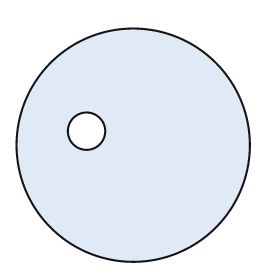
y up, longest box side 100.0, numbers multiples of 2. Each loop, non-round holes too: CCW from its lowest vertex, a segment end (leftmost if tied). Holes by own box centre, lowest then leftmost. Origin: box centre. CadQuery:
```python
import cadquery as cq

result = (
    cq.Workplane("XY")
    .moveTo(0.0, 0.0)
    .circle(50.0)
    .moveTo(-20.0, 6.0)
    .circle(8.0)
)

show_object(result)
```